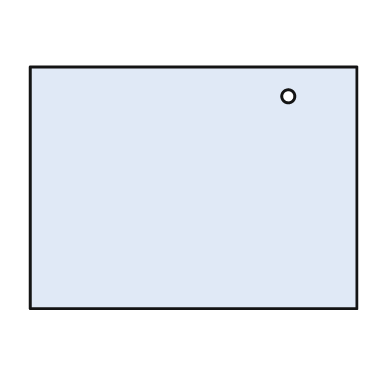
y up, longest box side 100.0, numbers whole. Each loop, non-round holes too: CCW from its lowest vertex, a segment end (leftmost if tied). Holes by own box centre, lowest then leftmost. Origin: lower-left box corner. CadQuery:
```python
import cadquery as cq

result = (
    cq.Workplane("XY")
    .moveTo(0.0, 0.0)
    .lineTo(100.0, 0.0)
    .lineTo(100.0, 74.0)
    .lineTo(0.0, 74.0)
    .close()
    .moveTo(79.0, 65.0)
    .circle(2.0)
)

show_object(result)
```